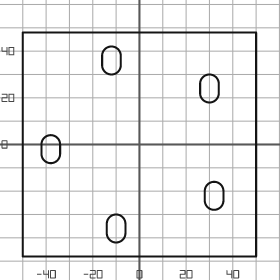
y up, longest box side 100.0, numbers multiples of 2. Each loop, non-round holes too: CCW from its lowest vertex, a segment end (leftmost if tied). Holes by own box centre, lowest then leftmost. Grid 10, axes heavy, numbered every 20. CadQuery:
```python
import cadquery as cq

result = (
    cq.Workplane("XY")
    .moveTo(-50.0, -48.0)
    .lineTo(50.0, -48.0)
    .lineTo(50.0, 48.0)
    .lineTo(-50.0, 48.0)
    .close()
    .moveTo(-14.0, -38.0)
    .threePointArc((-10.0, -42.0), (-6.0, -38.0))
    .lineTo(-6.0, -34.0)
    .threePointArc((-10.0, -30.0), (-14.0, -34.0))
    .close()
    .moveTo(28.0, -24.0)
    .threePointArc((32.0, -28.0), (36.0, -24.0))
    .lineTo(36.0, -20.0)
    .threePointArc((32.0, -16.0), (28.0, -20.0))
    .close()
    .moveTo(-42.0, -4.0)
    .threePointArc((-38.0, -8.0), (-34.0, -4.0))
    .lineTo(-34.0, 0.0)
    .threePointArc((-38.0, 4.0), (-42.0, 0.0))
    .close()
    .moveTo(26.0, 22.0)
    .threePointArc((30.0, 18.0), (34.0, 22.0))
    .lineTo(34.0, 26.0)
    .threePointArc((30.0, 30.0), (26.0, 26.0))
    .close()
    .moveTo(-16.0, 34.0)
    .threePointArc((-12.0, 30.0), (-8.0, 34.0))
    .lineTo(-8.0, 38.0)
    .threePointArc((-12.0, 42.0), (-16.0, 38.0))
    .close()
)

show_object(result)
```